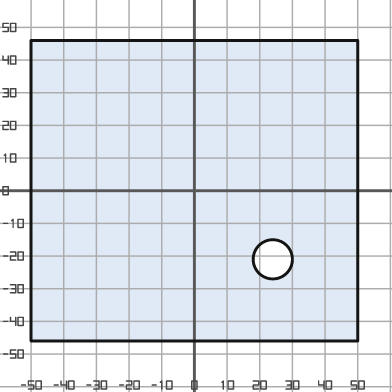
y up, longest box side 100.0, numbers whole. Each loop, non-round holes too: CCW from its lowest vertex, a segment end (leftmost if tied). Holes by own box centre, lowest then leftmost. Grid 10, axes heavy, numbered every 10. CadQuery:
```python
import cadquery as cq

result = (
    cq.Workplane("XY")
    .moveTo(-50.0, -46.0)
    .lineTo(50.0, -46.0)
    .lineTo(50.0, 46.0)
    .lineTo(-50.0, 46.0)
    .close()
    .moveTo(24.0, -21.0)
    .circle(6.0)
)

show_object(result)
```